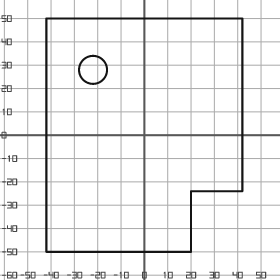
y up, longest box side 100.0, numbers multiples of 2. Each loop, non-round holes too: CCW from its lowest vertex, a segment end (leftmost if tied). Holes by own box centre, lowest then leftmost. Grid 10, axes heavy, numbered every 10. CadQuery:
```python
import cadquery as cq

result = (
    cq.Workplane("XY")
    .moveTo(-42.0, -50.0)
    .lineTo(20.0, -50.0)
    .lineTo(20.0, -24.0)
    .lineTo(42.0, -24.0)
    .lineTo(42.0, 50.0)
    .lineTo(-42.0, 50.0)
    .close()
    .moveTo(-22.0, 28.0)
    .circle(6.0)
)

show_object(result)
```